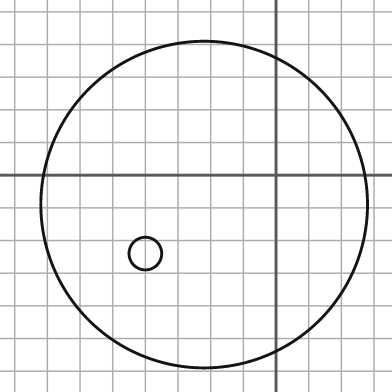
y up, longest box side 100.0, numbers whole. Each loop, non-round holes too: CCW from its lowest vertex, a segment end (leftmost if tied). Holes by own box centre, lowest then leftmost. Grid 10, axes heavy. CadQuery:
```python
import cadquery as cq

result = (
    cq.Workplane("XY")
    .moveTo(-22.0, -9.0)
    .circle(50.0)
    .moveTo(-40.0, -24.0)
    .circle(5.0)
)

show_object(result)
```